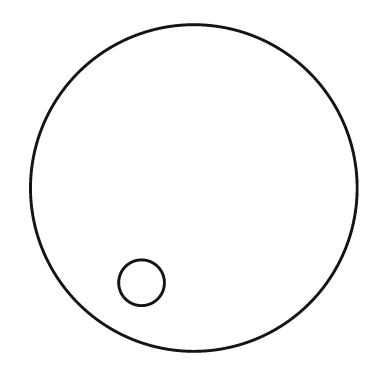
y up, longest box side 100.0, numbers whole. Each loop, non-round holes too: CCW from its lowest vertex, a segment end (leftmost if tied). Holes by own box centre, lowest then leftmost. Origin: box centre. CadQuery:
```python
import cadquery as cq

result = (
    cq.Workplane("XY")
    .moveTo(0.0, 0.0)
    .circle(50.0)
    .moveTo(-16.0, -29.0)
    .circle(7.0)
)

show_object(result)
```